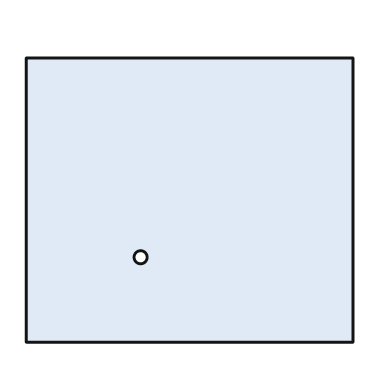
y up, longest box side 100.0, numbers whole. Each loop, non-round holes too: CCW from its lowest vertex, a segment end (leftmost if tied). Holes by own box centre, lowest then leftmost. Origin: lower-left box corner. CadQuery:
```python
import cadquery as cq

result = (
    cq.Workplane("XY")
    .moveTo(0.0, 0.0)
    .lineTo(100.0, 0.0)
    .lineTo(100.0, 87.0)
    .lineTo(0.0, 87.0)
    .close()
    .moveTo(35.0, 26.0)
    .circle(2.0)
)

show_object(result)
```